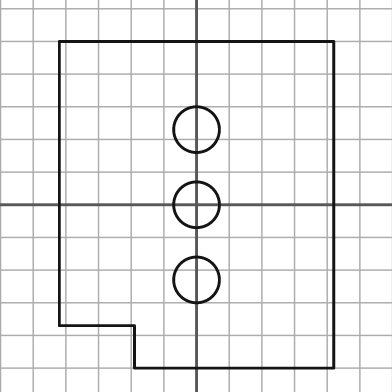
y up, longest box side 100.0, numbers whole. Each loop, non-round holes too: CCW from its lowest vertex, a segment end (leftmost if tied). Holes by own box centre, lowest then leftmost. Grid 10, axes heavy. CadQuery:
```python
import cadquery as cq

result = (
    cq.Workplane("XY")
    .moveTo(-19.0, -50.0)
    .lineTo(42.0, -50.0)
    .lineTo(42.0, 50.0)
    .lineTo(-42.0, 50.0)
    .lineTo(-42.0, -37.0)
    .lineTo(-19.0, -37.0)
    .close()
    .moveTo(0.0, -23.0)
    .circle(7.0)
    .moveTo(0.0, 0.0)
    .circle(7.0)
    .moveTo(0.0, 23.0)
    .circle(7.0)
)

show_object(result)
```